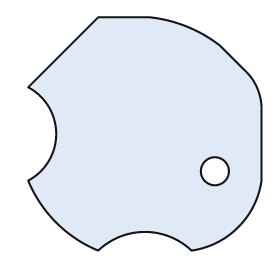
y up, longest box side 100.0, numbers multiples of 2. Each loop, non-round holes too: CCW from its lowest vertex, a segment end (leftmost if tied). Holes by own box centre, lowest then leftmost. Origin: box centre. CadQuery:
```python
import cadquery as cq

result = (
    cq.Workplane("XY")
    .moveTo(-20.0, -50.0)
    .threePointArc((0.0, -42.0), (20.0, -50.0))
    .threePointArc((40.0, -40.0), (50.0, -20.0))
    .lineTo(50.0, 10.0)
    .threePointArc((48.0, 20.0), (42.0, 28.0))
    .lineTo(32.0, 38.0)
    .threePointArc((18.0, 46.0), (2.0, 50.0))
    .lineTo(-20.0, 50.0)
    .lineTo(-50.0, 20.0)
    .threePointArc((-38.0, 0.0), (-50.0, -20.0))
    .threePointArc((-38.0, -38.0), (-20.0, -50.0))
    .close()
    .moveTo(30.0, -16.0)
    .circle(6.0)
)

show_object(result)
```